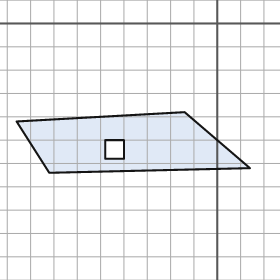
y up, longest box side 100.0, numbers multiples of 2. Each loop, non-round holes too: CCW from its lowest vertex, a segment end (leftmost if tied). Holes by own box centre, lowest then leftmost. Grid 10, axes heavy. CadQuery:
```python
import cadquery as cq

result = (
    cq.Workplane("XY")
    .moveTo(-72.0, -64.0)
    .lineTo(14.0, -62.0)
    .lineTo(-14.0, -38.0)
    .lineTo(-86.0, -42.0)
    .close()
    .moveTo(-48.0, -58.0)
    .lineTo(-40.0, -58.0)
    .lineTo(-40.0, -50.0)
    .lineTo(-48.0, -50.0)
    .close()
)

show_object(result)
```